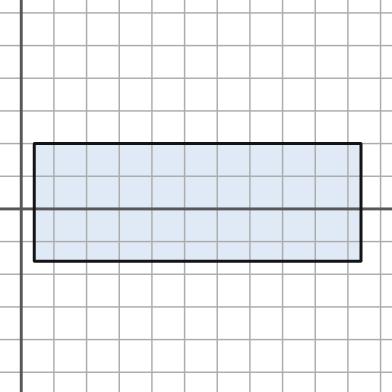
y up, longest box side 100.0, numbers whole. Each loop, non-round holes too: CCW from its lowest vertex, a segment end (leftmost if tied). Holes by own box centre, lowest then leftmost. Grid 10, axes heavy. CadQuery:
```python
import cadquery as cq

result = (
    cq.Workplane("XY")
    .moveTo(4.0, -16.0)
    .lineTo(104.0, -16.0)
    .lineTo(104.0, 20.0)
    .lineTo(4.0, 20.0)
    .close()
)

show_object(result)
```